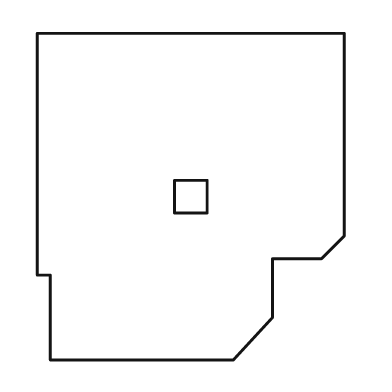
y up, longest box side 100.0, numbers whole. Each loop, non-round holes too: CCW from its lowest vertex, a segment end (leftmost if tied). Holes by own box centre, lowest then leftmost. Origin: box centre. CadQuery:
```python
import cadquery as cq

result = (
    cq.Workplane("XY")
    .moveTo(-43.0, -50.0)
    .lineTo(13.0, -50.0)
    .lineTo(25.0, -37.0)
    .lineTo(25.0, -19.0)
    .lineTo(40.0, -19.0)
    .lineTo(47.0, -12.0)
    .lineTo(47.0, 50.0)
    .lineTo(-47.0, 50.0)
    .lineTo(-47.0, -24.0)
    .lineTo(-43.0, -24.0)
    .close()
    .moveTo(-5.0, -5.0)
    .lineTo(5.0, -5.0)
    .lineTo(5.0, 5.0)
    .lineTo(-5.0, 5.0)
    .close()
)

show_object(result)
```